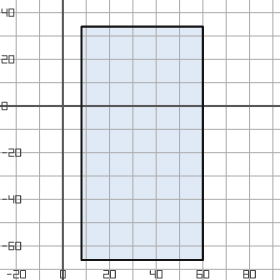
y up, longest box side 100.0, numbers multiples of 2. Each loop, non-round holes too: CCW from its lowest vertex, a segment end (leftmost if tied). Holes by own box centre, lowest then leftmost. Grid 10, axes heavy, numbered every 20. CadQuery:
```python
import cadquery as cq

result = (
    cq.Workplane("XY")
    .moveTo(8.0, -66.0)
    .lineTo(60.0, -66.0)
    .lineTo(60.0, 34.0)
    .lineTo(8.0, 34.0)
    .close()
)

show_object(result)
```